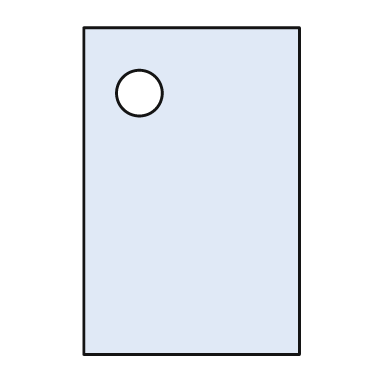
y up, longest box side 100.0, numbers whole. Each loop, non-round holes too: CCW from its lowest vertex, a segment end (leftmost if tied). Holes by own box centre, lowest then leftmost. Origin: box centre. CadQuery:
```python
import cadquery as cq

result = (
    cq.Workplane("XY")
    .moveTo(-33.0, -50.0)
    .lineTo(33.0, -50.0)
    .lineTo(33.0, 50.0)
    .lineTo(-33.0, 50.0)
    .close()
    .moveTo(-16.0, 30.0)
    .circle(7.0)
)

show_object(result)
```